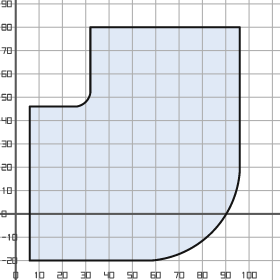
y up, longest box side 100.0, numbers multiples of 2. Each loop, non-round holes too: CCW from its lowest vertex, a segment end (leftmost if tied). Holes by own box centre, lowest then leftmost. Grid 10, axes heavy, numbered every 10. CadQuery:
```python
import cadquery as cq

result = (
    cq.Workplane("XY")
    .moveTo(6.0, -20.0)
    .lineTo(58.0, -20.0)
    .threePointArc((84.0, -8.0), (96.0, 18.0))
    .lineTo(96.0, 80.0)
    .lineTo(32.0, 80.0)
    .lineTo(32.0, 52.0)
    .threePointArc((30.0, 48.0), (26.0, 46.0))
    .lineTo(6.0, 46.0)
    .close()
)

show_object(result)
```